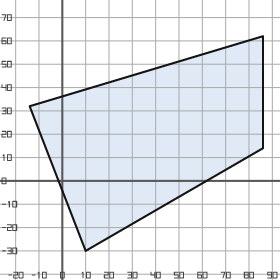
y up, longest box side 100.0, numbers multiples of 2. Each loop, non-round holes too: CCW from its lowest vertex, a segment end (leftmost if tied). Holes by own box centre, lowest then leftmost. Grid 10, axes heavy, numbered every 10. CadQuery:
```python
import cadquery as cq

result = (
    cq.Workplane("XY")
    .moveTo(10.0, -30.0)
    .lineTo(86.0, 14.0)
    .lineTo(86.0, 62.0)
    .lineTo(-14.0, 32.0)
    .close()
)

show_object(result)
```